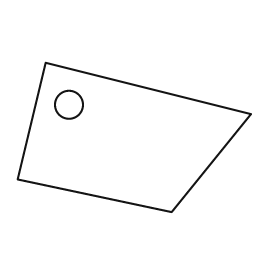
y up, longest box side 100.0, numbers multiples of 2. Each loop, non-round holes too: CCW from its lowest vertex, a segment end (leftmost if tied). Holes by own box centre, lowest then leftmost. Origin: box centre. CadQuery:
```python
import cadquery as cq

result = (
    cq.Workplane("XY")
    .moveTo(16.0, -32.0)
    .lineTo(50.0, 10.0)
    .lineTo(-38.0, 32.0)
    .lineTo(-50.0, -18.0)
    .close()
    .moveTo(-28.0, 14.0)
    .circle(6.0)
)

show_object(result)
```